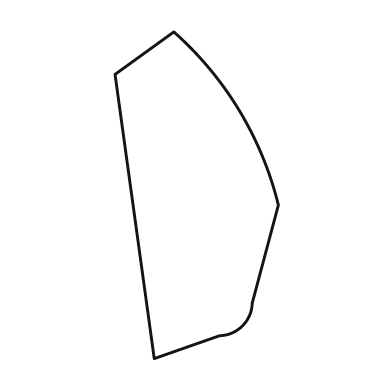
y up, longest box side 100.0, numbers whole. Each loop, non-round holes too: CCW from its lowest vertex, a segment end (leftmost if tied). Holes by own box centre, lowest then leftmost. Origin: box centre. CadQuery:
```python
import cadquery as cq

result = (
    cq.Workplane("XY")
    .moveTo(-13.0, -50.0)
    .lineTo(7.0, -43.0)
    .threePointArc((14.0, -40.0), (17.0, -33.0))
    .lineTo(25.0, -3.0)
    .threePointArc((13.0, 26.0), (-7.0, 50.0))
    .lineTo(-25.0, 37.0)
    .close()
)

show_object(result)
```